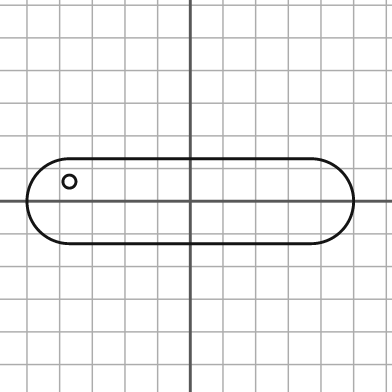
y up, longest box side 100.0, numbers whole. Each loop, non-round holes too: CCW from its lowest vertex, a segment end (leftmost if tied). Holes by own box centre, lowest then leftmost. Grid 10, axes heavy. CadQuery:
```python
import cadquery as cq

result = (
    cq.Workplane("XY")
    .moveTo(-37.0, -13.0)
    .lineTo(37.0, -13.0)
    .threePointArc((50.0, 0.0), (37.0, 13.0))
    .lineTo(-37.0, 13.0)
    .threePointArc((-50.0, 0.0), (-37.0, -13.0))
    .close()
    .moveTo(-37.0, 6.0)
    .circle(2.0)
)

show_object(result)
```